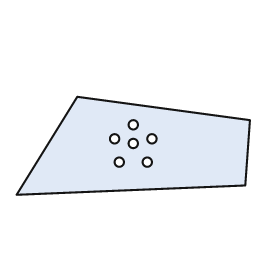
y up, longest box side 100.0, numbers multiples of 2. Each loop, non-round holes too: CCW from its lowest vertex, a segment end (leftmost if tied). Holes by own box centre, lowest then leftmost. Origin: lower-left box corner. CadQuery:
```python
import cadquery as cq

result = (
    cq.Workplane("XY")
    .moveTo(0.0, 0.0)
    .lineTo(98.0, 4.0)
    .lineTo(100.0, 32.0)
    .lineTo(26.0, 42.0)
    .close()
    .moveTo(44.0, 14.0)
    .circle(2.0)
    .moveTo(56.0, 14.0)
    .circle(2.0)
    .moveTo(50.0, 22.0)
    .circle(2.0)
    .moveTo(42.0, 24.0)
    .circle(2.0)
    .moveTo(58.0, 24.0)
    .circle(2.0)
    .moveTo(50.0, 30.0)
    .circle(2.0)
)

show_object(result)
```